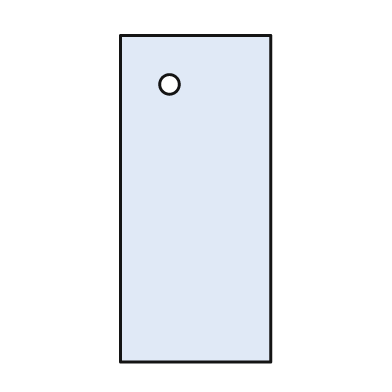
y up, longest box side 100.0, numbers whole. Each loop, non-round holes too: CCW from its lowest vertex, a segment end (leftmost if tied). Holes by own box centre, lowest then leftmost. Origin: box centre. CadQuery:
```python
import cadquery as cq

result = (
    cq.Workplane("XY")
    .moveTo(-23.0, -50.0)
    .lineTo(23.0, -50.0)
    .lineTo(23.0, 50.0)
    .lineTo(-23.0, 50.0)
    .close()
    .moveTo(-8.0, 35.0)
    .circle(3.0)
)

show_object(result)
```